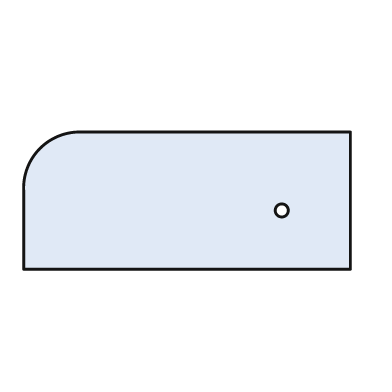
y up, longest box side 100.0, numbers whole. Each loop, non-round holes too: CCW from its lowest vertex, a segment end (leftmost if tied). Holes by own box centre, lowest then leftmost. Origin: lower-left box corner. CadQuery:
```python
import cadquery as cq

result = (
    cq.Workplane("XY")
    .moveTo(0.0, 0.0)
    .lineTo(100.0, 0.0)
    .lineTo(100.0, 42.0)
    .lineTo(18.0, 42.0)
    .threePointArc((5.0, 37.0), (0.0, 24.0))
    .close()
    .moveTo(79.0, 18.0)
    .circle(2.0)
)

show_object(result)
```